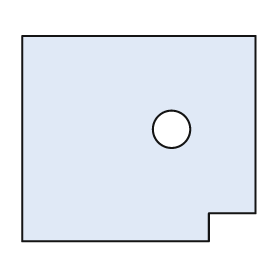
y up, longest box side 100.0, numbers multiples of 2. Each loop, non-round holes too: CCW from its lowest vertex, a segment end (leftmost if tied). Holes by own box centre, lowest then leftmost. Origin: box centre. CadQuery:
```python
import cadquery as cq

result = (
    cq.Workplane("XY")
    .moveTo(-50.0, -44.0)
    .lineTo(30.0, -44.0)
    .lineTo(30.0, -32.0)
    .lineTo(50.0, -32.0)
    .lineTo(50.0, 44.0)
    .lineTo(-50.0, 44.0)
    .close()
    .moveTo(14.0, 4.0)
    .circle(8.0)
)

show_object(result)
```